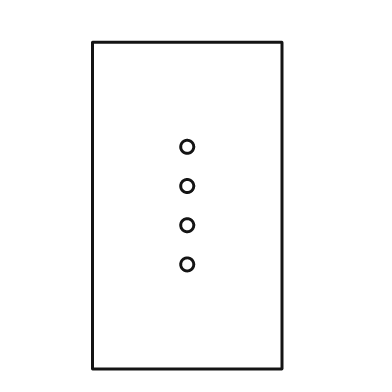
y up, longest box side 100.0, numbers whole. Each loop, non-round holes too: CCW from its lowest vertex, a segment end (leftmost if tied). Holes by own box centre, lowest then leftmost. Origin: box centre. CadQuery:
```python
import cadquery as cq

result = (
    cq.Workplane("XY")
    .moveTo(-29.0, -50.0)
    .lineTo(29.0, -50.0)
    .lineTo(29.0, 50.0)
    .lineTo(-29.0, 50.0)
    .close()
    .moveTo(0.0, -18.0)
    .circle(2.0)
    .moveTo(0.0, -6.0)
    .circle(2.0)
    .moveTo(0.0, 6.0)
    .circle(2.0)
    .moveTo(0.0, 18.0)
    .circle(2.0)
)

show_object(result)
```